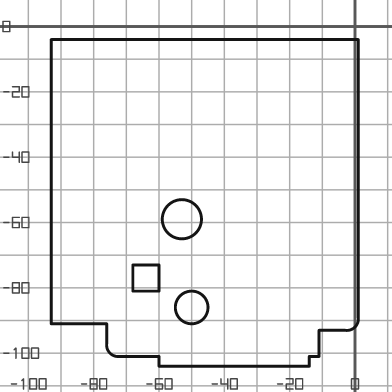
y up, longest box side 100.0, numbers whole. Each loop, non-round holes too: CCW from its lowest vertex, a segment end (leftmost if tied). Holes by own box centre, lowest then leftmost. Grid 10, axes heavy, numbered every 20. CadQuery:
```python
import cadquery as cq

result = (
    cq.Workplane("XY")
    .moveTo(-60.0, -104.0)
    .lineTo(-14.0, -104.0)
    .lineTo(-14.0, -101.0)
    .lineTo(-11.0, -101.0)
    .lineTo(-11.0, -93.0)
    .lineTo(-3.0, -93.0)
    .threePointArc((0.0, -92.0), (1.0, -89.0))
    .lineTo(1.0, -4.0)
    .lineTo(-93.0, -4.0)
    .lineTo(-93.0, -91.0)
    .lineTo(-76.0, -91.0)
    .lineTo(-76.0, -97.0)
    .threePointArc((-75.0, -100.0), (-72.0, -101.0))
    .lineTo(-60.0, -101.0)
    .close()
    .moveTo(-50.0, -86.0)
    .circle(5.0)
    .moveTo(-68.0, -81.0)
    .lineTo(-60.0, -81.0)
    .lineTo(-60.0, -73.0)
    .lineTo(-68.0, -73.0)
    .close()
    .moveTo(-53.0, -59.0)
    .circle(6.0)
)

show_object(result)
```